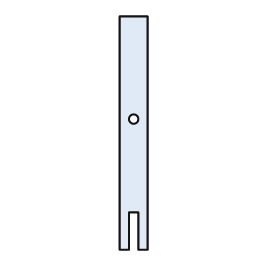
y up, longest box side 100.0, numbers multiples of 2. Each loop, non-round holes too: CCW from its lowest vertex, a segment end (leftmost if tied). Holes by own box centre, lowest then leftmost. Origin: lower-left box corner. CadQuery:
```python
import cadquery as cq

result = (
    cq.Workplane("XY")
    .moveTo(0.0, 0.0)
    .lineTo(4.0, 0.0)
    .lineTo(4.0, 16.0)
    .lineTo(8.0, 16.0)
    .lineTo(8.0, 0.0)
    .lineTo(12.0, 0.0)
    .lineTo(12.0, 100.0)
    .lineTo(0.0, 100.0)
    .close()
    .moveTo(6.0, 56.0)
    .circle(2.0)
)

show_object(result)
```